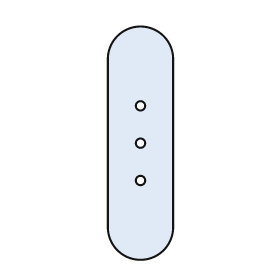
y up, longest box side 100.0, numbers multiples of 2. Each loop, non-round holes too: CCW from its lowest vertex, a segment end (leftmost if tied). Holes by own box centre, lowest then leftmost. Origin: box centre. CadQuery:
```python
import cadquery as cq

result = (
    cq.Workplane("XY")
    .moveTo(-14.0, -36.0)
    .threePointArc((0.0, -50.0), (14.0, -36.0))
    .lineTo(14.0, 36.0)
    .threePointArc((0.0, 50.0), (-14.0, 36.0))
    .close()
    .moveTo(0.0, -16.0)
    .circle(2.0)
    .moveTo(0.0, 0.0)
    .circle(2.0)
    .moveTo(0.0, 16.0)
    .circle(2.0)
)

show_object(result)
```